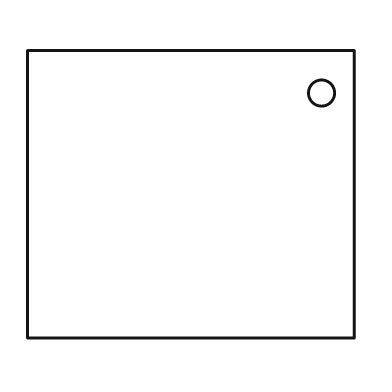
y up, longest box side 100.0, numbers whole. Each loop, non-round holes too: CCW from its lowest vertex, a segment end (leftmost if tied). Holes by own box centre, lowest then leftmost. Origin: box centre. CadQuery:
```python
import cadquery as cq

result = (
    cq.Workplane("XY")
    .moveTo(-50.0, -44.0)
    .lineTo(50.0, -44.0)
    .lineTo(50.0, 44.0)
    .lineTo(-50.0, 44.0)
    .close()
    .moveTo(40.0, 31.0)
    .circle(4.0)
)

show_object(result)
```